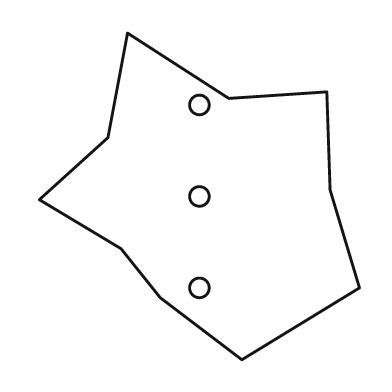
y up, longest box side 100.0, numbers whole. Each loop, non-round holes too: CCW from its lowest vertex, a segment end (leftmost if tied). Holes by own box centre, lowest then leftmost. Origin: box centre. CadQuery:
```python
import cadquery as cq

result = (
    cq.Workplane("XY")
    .moveTo(13.0, -50.0)
    .lineTo(49.0, -28.0)
    .lineTo(40.0, 2.0)
    .lineTo(39.0, 32.0)
    .lineTo(9.0, 30.0)
    .lineTo(-22.0, 50.0)
    .lineTo(-28.0, 18.0)
    .lineTo(-49.0, -1.0)
    .lineTo(-24.0, -16.0)
    .lineTo(-12.0, -31.0)
    .close()
    .moveTo(0.0, -28.0)
    .circle(3.0)
    .moveTo(0.0, 0.0)
    .circle(3.0)
    .moveTo(0.0, 28.0)
    .circle(3.0)
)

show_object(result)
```